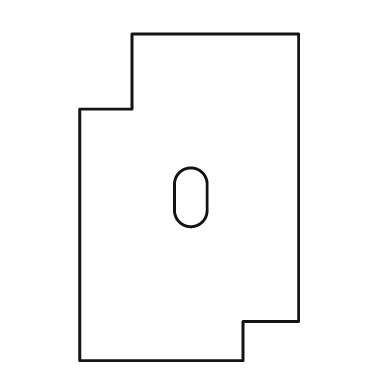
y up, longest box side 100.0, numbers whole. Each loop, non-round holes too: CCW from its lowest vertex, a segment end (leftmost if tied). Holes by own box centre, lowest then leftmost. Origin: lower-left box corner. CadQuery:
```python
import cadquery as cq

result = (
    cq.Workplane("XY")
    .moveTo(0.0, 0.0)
    .lineTo(50.0, 0.0)
    .lineTo(50.0, 12.0)
    .lineTo(67.0, 12.0)
    .lineTo(67.0, 100.0)
    .lineTo(16.0, 100.0)
    .lineTo(16.0, 77.0)
    .lineTo(0.0, 77.0)
    .close()
    .moveTo(29.0, 46.0)
    .threePointArc((34.0, 41.0), (39.0, 46.0))
    .lineTo(39.0, 54.0)
    .threePointArc((34.0, 59.0), (29.0, 54.0))
    .close()
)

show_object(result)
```